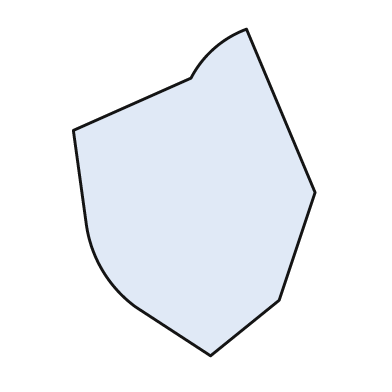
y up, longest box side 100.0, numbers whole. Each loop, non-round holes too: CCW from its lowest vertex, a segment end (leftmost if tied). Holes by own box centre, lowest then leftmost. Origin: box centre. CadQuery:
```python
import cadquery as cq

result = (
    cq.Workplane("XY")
    .moveTo(5.0, -50.0)
    .lineTo(26.0, -33.0)
    .lineTo(37.0, 0.0)
    .lineTo(16.0, 50.0)
    .threePointArc((6.0, 44.0), (-1.0, 35.0))
    .lineTo(-37.0, 19.0)
    .lineTo(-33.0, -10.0)
    .threePointArc((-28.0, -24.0), (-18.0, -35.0))
    .close()
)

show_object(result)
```